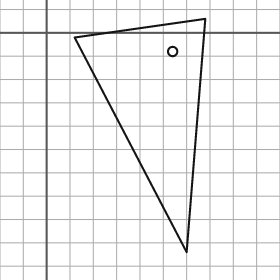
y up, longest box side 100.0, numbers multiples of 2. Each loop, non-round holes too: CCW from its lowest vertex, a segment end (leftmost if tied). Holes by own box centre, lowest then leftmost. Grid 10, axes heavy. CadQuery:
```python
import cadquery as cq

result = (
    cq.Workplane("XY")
    .moveTo(60.0, -94.0)
    .lineTo(68.0, 6.0)
    .lineTo(12.0, -2.0)
    .close()
    .moveTo(54.0, -8.0)
    .circle(2.0)
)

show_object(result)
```